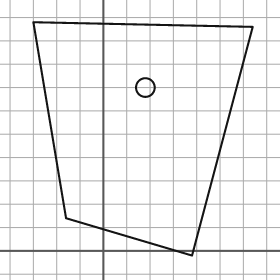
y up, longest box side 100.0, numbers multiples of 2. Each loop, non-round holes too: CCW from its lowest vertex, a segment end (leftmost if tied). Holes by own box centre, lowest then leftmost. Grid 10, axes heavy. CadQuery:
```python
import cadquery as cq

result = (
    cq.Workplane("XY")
    .moveTo(38.0, -2.0)
    .lineTo(64.0, 96.0)
    .lineTo(-30.0, 98.0)
    .lineTo(-16.0, 14.0)
    .close()
    .moveTo(18.0, 70.0)
    .circle(4.0)
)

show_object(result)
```